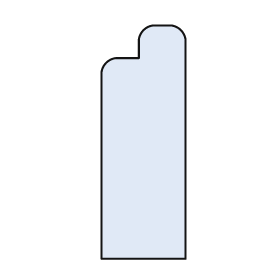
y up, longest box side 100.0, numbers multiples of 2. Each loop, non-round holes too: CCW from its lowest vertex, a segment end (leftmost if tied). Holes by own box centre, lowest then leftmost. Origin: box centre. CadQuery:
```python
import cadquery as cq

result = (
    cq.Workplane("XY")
    .moveTo(-18.0, -50.0)
    .lineTo(18.0, -50.0)
    .lineTo(18.0, 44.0)
    .threePointArc((16.0, 48.0), (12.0, 50.0))
    .lineTo(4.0, 50.0)
    .threePointArc((0.0, 48.0), (-2.0, 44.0))
    .lineTo(-2.0, 36.0)
    .lineTo(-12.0, 36.0)
    .threePointArc((-16.0, 34.0), (-18.0, 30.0))
    .close()
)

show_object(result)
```